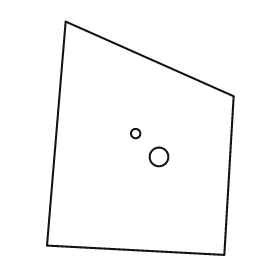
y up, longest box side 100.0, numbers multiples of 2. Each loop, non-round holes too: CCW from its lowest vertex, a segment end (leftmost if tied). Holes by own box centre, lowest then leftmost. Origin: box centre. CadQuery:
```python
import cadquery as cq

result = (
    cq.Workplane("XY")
    .moveTo(36.0, -50.0)
    .lineTo(40.0, 18.0)
    .lineTo(-32.0, 50.0)
    .lineTo(-40.0, -46.0)
    .close()
    .moveTo(8.0, -8.0)
    .circle(4.0)
    .moveTo(-2.0, 2.0)
    .circle(2.0)
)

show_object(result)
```